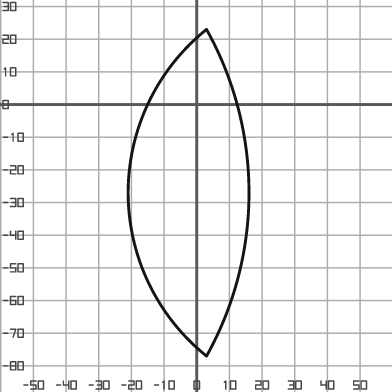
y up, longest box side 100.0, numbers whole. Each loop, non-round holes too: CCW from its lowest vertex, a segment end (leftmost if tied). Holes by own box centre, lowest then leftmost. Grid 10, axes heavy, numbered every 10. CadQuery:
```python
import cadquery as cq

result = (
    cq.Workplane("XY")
    .moveTo(3.0, -77.0)
    .threePointArc((16.0, -27.0), (3.0, 23.0))
    .threePointArc((-21.0, -27.0), (3.0, -77.0))
    .close()
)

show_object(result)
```